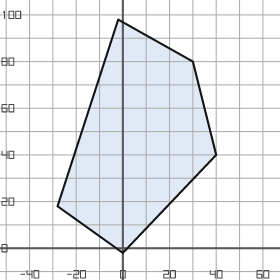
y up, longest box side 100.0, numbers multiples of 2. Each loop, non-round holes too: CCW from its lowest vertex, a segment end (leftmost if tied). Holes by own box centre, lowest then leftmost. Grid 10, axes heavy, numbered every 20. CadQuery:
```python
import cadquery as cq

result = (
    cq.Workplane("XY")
    .moveTo(0.0, -2.0)
    .lineTo(40.0, 40.0)
    .lineTo(30.0, 80.0)
    .lineTo(-2.0, 98.0)
    .lineTo(-28.0, 18.0)
    .close()
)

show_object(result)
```